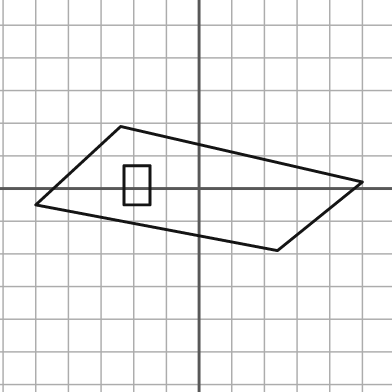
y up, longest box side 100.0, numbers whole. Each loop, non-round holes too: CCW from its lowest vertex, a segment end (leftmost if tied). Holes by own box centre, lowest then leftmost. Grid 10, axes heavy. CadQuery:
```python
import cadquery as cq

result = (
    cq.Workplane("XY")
    .moveTo(24.0, -19.0)
    .lineTo(50.0, 2.0)
    .lineTo(-24.0, 19.0)
    .lineTo(-50.0, -5.0)
    .close()
    .moveTo(-23.0, -5.0)
    .lineTo(-15.0, -5.0)
    .lineTo(-15.0, 7.0)
    .lineTo(-23.0, 7.0)
    .close()
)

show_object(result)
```